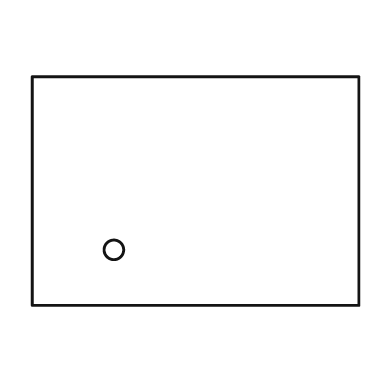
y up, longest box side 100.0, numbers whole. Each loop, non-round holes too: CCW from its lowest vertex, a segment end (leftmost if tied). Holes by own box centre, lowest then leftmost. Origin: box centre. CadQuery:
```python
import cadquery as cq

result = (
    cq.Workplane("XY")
    .moveTo(-50.0, -35.0)
    .lineTo(50.0, -35.0)
    .lineTo(50.0, 35.0)
    .lineTo(-50.0, 35.0)
    .close()
    .moveTo(-25.0, -18.0)
    .circle(3.0)
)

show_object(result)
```